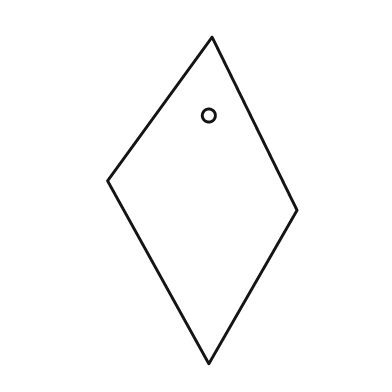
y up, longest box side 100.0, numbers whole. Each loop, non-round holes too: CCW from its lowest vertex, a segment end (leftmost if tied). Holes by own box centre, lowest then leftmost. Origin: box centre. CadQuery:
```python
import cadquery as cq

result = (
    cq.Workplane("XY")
    .moveTo(2.0, -50.0)
    .lineTo(29.0, -3.0)
    .lineTo(3.0, 50.0)
    .lineTo(-29.0, 6.0)
    .close()
    .moveTo(2.0, 26.0)
    .circle(2.0)
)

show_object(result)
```